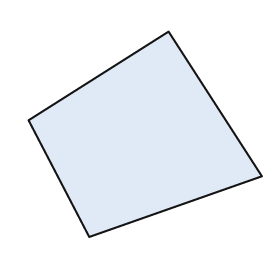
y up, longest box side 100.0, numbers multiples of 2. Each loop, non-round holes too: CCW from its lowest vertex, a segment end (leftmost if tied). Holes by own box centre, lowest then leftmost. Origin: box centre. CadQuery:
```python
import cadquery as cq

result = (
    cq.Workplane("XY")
    .moveTo(-24.0, -44.0)
    .lineTo(50.0, -18.0)
    .lineTo(10.0, 44.0)
    .lineTo(-50.0, 6.0)
    .close()
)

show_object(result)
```